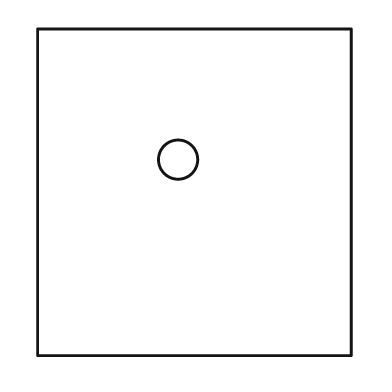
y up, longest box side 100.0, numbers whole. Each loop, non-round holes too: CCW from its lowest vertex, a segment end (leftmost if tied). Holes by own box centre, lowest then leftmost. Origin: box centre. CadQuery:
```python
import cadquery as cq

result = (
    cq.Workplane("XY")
    .moveTo(-48.0, -50.0)
    .lineTo(48.0, -50.0)
    .lineTo(48.0, 50.0)
    .lineTo(-48.0, 50.0)
    .close()
    .moveTo(-5.0, 10.0)
    .circle(6.0)
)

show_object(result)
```